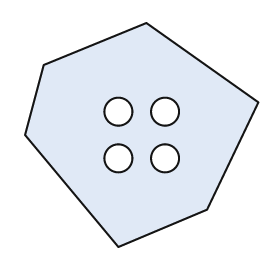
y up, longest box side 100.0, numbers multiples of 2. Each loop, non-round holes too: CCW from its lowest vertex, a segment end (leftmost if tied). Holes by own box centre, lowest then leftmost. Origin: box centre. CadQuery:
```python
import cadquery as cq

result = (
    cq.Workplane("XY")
    .moveTo(-10.0, -48.0)
    .lineTo(28.0, -32.0)
    .lineTo(50.0, 14.0)
    .lineTo(2.0, 48.0)
    .lineTo(-42.0, 30.0)
    .lineTo(-50.0, 0.0)
    .close()
    .moveTo(-10.0, -10.0)
    .circle(6.0)
    .moveTo(10.0, -10.0)
    .circle(6.0)
    .moveTo(-10.0, 10.0)
    .circle(6.0)
    .moveTo(10.0, 10.0)
    .circle(6.0)
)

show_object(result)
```